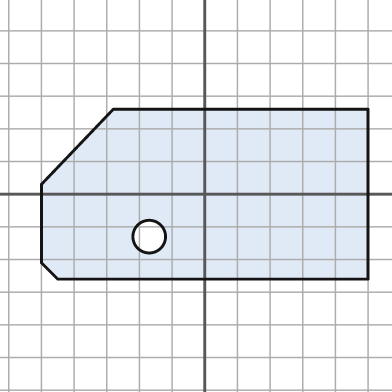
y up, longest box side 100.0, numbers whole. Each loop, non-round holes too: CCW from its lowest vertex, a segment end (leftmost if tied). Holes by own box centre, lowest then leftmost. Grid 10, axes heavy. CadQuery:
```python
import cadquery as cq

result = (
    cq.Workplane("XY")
    .moveTo(-45.0, -26.0)
    .lineTo(50.0, -26.0)
    .lineTo(50.0, 26.0)
    .lineTo(-28.0, 26.0)
    .lineTo(-50.0, 3.0)
    .lineTo(-50.0, -21.0)
    .close()
    .moveTo(-17.0, -13.0)
    .circle(5.0)
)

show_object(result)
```